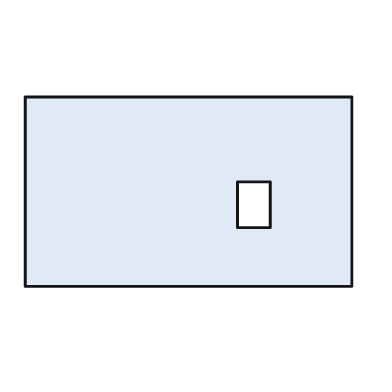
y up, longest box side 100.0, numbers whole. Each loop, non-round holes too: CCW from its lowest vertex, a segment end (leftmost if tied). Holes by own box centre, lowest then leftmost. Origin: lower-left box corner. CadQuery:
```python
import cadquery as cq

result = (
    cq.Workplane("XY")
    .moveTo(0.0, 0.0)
    .lineTo(100.0, 0.0)
    .lineTo(100.0, 58.0)
    .lineTo(0.0, 58.0)
    .close()
    .moveTo(65.0, 18.0)
    .lineTo(75.0, 18.0)
    .lineTo(75.0, 32.0)
    .lineTo(65.0, 32.0)
    .close()
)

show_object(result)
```